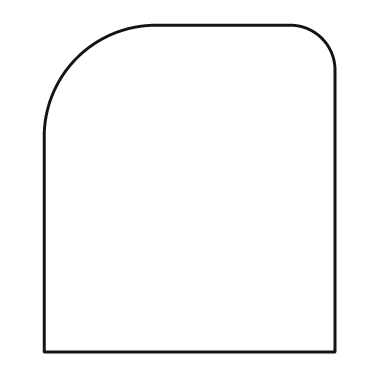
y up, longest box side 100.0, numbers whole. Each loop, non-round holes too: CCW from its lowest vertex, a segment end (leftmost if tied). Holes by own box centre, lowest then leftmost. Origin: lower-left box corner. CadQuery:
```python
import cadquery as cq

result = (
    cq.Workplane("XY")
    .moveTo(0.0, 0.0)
    .lineTo(89.0, 0.0)
    .lineTo(89.0, 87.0)
    .threePointArc((85.0, 96.0), (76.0, 100.0))
    .lineTo(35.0, 100.0)
    .threePointArc((10.0, 90.0), (0.0, 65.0))
    .close()
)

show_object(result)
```